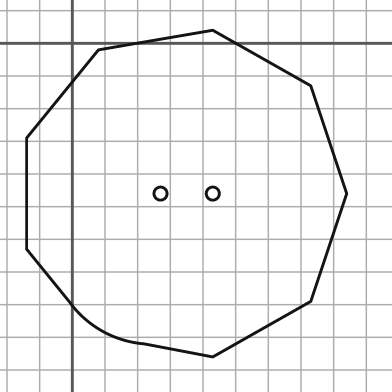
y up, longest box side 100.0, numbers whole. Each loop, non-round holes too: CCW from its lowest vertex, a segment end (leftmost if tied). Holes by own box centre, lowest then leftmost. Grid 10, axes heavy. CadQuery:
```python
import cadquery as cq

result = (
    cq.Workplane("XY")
    .moveTo(43.0, -96.0)
    .lineTo(73.0, -79.0)
    .lineTo(84.0, -46.0)
    .lineTo(73.0, -13.0)
    .lineTo(43.0, 4.0)
    .lineTo(8.0, -2.0)
    .lineTo(-14.0, -29.0)
    .lineTo(-14.0, -63.0)
    .lineTo(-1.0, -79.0)
    .threePointArc((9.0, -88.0), (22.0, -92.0))
    .close()
    .moveTo(27.0, -46.0)
    .circle(2.0)
    .moveTo(43.0, -46.0)
    .circle(2.0)
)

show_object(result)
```